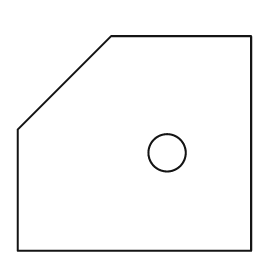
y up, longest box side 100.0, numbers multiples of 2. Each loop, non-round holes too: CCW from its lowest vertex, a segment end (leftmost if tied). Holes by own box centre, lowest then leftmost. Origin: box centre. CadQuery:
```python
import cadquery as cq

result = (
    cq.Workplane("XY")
    .moveTo(-50.0, -46.0)
    .lineTo(50.0, -46.0)
    .lineTo(50.0, 46.0)
    .lineTo(-10.0, 46.0)
    .lineTo(-50.0, 6.0)
    .close()
    .moveTo(14.0, -4.0)
    .circle(8.0)
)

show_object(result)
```